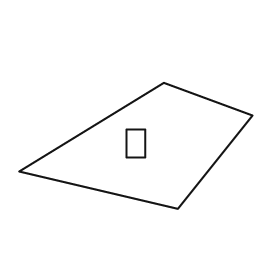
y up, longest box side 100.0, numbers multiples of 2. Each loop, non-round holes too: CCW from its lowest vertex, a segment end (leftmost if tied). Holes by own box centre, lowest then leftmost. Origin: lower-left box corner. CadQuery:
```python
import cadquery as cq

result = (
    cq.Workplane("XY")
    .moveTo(68.0, 0.0)
    .lineTo(100.0, 40.0)
    .lineTo(62.0, 54.0)
    .lineTo(0.0, 16.0)
    .close()
    .moveTo(46.0, 22.0)
    .lineTo(54.0, 22.0)
    .lineTo(54.0, 34.0)
    .lineTo(46.0, 34.0)
    .close()
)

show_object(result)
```